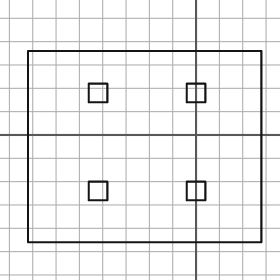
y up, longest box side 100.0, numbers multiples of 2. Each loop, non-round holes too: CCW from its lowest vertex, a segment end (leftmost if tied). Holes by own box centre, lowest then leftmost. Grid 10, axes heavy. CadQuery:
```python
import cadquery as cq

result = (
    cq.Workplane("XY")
    .moveTo(-72.0, -46.0)
    .lineTo(28.0, -46.0)
    .lineTo(28.0, 36.0)
    .lineTo(-72.0, 36.0)
    .close()
    .moveTo(-46.0, -28.0)
    .lineTo(-38.0, -28.0)
    .lineTo(-38.0, -20.0)
    .lineTo(-46.0, -20.0)
    .close()
    .moveTo(-4.0, -28.0)
    .lineTo(4.0, -28.0)
    .lineTo(4.0, -20.0)
    .lineTo(-4.0, -20.0)
    .close()
    .moveTo(-46.0, 14.0)
    .lineTo(-38.0, 14.0)
    .lineTo(-38.0, 22.0)
    .lineTo(-46.0, 22.0)
    .close()
    .moveTo(-4.0, 14.0)
    .lineTo(4.0, 14.0)
    .lineTo(4.0, 22.0)
    .lineTo(-4.0, 22.0)
    .close()
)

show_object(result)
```